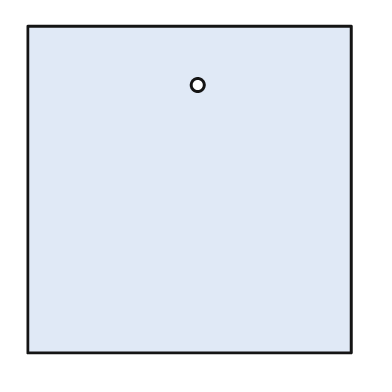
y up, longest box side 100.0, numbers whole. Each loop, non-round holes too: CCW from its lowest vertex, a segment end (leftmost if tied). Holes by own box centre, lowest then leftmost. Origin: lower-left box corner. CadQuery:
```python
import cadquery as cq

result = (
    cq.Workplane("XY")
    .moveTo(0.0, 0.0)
    .lineTo(99.0, 0.0)
    .lineTo(99.0, 100.0)
    .lineTo(0.0, 100.0)
    .close()
    .moveTo(52.0, 82.0)
    .circle(2.0)
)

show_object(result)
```